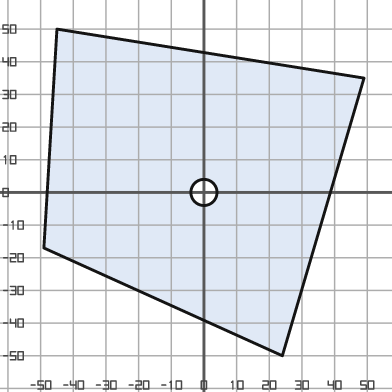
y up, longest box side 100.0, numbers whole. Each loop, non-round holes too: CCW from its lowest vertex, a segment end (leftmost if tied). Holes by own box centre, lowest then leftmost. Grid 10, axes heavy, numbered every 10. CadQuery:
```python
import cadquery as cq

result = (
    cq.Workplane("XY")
    .moveTo(24.0, -50.0)
    .lineTo(49.0, 35.0)
    .lineTo(-45.0, 50.0)
    .lineTo(-49.0, -17.0)
    .close()
    .moveTo(0.0, 0.0)
    .circle(4.0)
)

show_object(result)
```